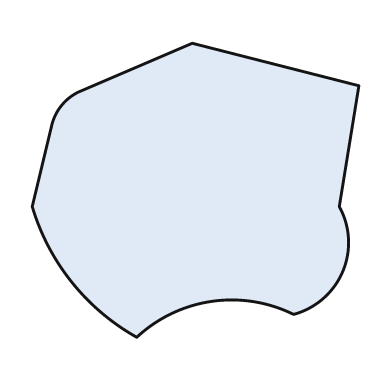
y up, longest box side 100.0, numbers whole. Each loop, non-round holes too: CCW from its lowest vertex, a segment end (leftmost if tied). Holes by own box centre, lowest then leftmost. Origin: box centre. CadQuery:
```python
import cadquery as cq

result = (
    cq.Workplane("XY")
    .moveTo(-18.0, -45.0)
    .threePointArc((5.0, -34.0), (30.0, -38.0))
    .threePointArc((45.0, -25.0), (44.0, -5.0))
    .lineTo(50.0, 32.0)
    .lineTo(-1.0, 45.0)
    .lineTo(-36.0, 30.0)
    .threePointArc((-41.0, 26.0), (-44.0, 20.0))
    .lineTo(-50.0, -5.0)
    .threePointArc((-38.0, -28.0), (-18.0, -45.0))
    .close()
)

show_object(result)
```